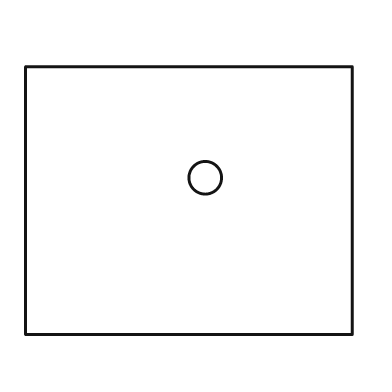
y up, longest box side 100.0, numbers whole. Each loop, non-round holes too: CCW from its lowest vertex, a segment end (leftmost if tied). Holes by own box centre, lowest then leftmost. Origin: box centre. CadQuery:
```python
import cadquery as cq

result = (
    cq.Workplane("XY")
    .moveTo(-50.0, -41.0)
    .lineTo(50.0, -41.0)
    .lineTo(50.0, 41.0)
    .lineTo(-50.0, 41.0)
    .close()
    .moveTo(5.0, 7.0)
    .circle(5.0)
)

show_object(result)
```